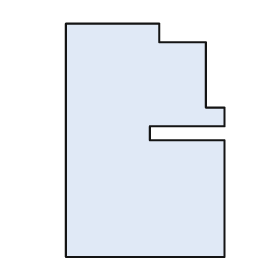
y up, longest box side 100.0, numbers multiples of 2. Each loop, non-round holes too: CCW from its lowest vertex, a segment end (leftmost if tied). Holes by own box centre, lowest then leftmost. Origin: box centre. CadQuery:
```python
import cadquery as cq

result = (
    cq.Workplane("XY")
    .moveTo(-34.0, -50.0)
    .lineTo(34.0, -50.0)
    .lineTo(34.0, 0.0)
    .lineTo(2.0, 0.0)
    .lineTo(2.0, 6.0)
    .lineTo(34.0, 6.0)
    .lineTo(34.0, 14.0)
    .lineTo(26.0, 14.0)
    .lineTo(26.0, 42.0)
    .lineTo(6.0, 42.0)
    .lineTo(6.0, 50.0)
    .lineTo(-34.0, 50.0)
    .close()
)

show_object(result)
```